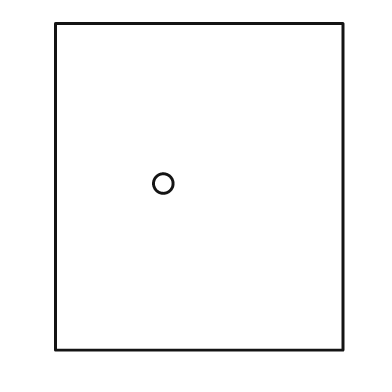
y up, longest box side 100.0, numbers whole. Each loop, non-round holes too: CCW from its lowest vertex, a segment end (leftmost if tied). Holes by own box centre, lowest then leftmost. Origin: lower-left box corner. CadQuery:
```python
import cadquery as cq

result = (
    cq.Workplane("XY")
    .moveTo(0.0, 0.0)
    .lineTo(88.0, 0.0)
    .lineTo(88.0, 100.0)
    .lineTo(0.0, 100.0)
    .close()
    .moveTo(33.0, 51.0)
    .circle(3.0)
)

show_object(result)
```